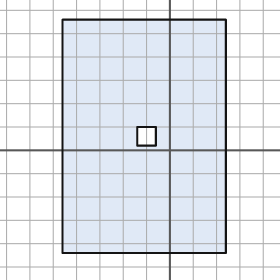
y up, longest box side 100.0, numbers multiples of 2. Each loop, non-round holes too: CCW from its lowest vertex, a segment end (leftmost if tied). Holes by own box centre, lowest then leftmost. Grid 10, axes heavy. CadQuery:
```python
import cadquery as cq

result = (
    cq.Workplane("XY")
    .moveTo(-46.0, -44.0)
    .lineTo(24.0, -44.0)
    .lineTo(24.0, 56.0)
    .lineTo(-46.0, 56.0)
    .close()
    .moveTo(-14.0, 2.0)
    .lineTo(-6.0, 2.0)
    .lineTo(-6.0, 10.0)
    .lineTo(-14.0, 10.0)
    .close()
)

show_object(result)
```